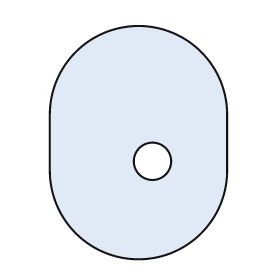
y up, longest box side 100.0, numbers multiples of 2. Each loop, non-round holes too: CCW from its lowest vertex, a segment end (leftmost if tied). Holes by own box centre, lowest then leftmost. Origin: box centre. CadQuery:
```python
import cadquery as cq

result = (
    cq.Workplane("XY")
    .moveTo(-38.0, -12.0)
    .threePointArc((0.0, -50.0), (38.0, -12.0))
    .lineTo(38.0, 12.0)
    .threePointArc((0.0, 50.0), (-38.0, 12.0))
    .close()
    .moveTo(6.0, -8.0)
    .circle(8.0)
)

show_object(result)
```